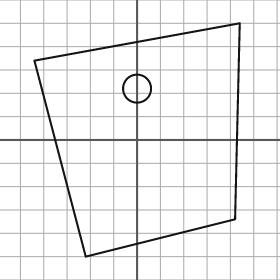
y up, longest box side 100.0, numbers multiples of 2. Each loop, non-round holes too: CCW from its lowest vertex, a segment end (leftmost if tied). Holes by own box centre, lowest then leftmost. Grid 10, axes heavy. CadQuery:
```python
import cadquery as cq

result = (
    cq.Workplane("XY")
    .moveTo(-22.0, -50.0)
    .lineTo(42.0, -34.0)
    .lineTo(44.0, 50.0)
    .lineTo(-44.0, 34.0)
    .close()
    .moveTo(0.0, 22.0)
    .circle(6.0)
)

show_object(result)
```